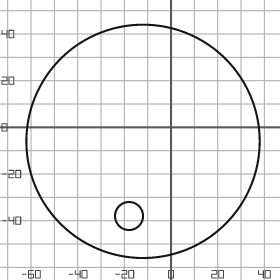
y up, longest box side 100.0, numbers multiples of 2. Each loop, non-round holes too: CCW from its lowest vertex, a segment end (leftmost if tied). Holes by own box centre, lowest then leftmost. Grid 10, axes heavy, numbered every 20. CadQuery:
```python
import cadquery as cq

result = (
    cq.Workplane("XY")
    .moveTo(-12.0, -6.0)
    .circle(50.0)
    .moveTo(-18.0, -38.0)
    .circle(6.0)
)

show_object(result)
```